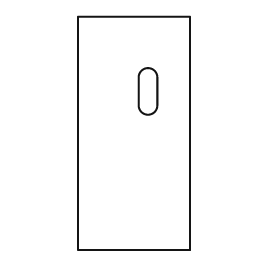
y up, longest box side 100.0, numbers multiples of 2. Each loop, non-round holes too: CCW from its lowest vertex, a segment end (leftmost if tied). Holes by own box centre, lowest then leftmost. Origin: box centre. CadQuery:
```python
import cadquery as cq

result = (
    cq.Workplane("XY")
    .moveTo(-24.0, -50.0)
    .lineTo(24.0, -50.0)
    .lineTo(24.0, 50.0)
    .lineTo(-24.0, 50.0)
    .close()
    .moveTo(2.0, 12.0)
    .threePointArc((6.0, 8.0), (10.0, 12.0))
    .lineTo(10.0, 24.0)
    .threePointArc((6.0, 28.0), (2.0, 24.0))
    .close()
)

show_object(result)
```